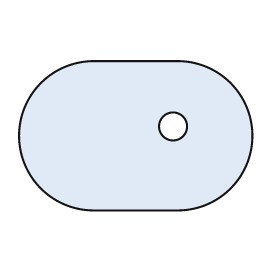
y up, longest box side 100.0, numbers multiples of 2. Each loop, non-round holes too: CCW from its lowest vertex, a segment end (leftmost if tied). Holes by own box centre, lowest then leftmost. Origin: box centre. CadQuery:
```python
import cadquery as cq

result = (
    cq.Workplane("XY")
    .moveTo(-18.0, -32.0)
    .lineTo(18.0, -32.0)
    .threePointArc((50.0, 0.0), (18.0, 32.0))
    .lineTo(-18.0, 32.0)
    .threePointArc((-50.0, 0.0), (-18.0, -32.0))
    .close()
    .moveTo(16.0, 4.0)
    .circle(6.0)
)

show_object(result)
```